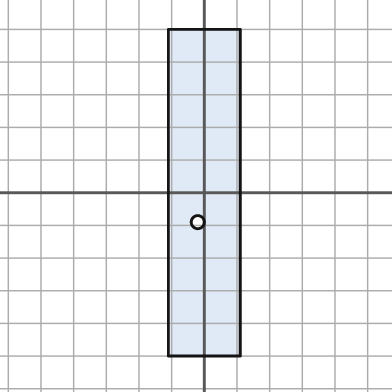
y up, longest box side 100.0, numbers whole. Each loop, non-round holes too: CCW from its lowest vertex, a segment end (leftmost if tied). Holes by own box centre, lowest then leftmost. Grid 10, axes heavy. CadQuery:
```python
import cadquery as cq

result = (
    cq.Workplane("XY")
    .moveTo(-11.0, -50.0)
    .lineTo(11.0, -50.0)
    .lineTo(11.0, 50.0)
    .lineTo(-11.0, 50.0)
    .close()
    .moveTo(-2.0, -9.0)
    .circle(2.0)
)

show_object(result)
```